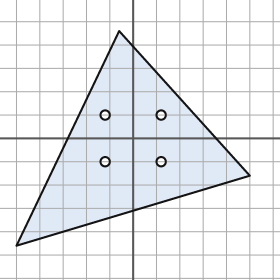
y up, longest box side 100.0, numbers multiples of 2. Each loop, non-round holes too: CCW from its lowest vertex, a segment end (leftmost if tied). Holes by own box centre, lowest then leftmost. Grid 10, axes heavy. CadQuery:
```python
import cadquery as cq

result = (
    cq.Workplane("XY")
    .moveTo(-50.0, -46.0)
    .lineTo(50.0, -16.0)
    .lineTo(-6.0, 46.0)
    .close()
    .moveTo(-12.0, -10.0)
    .circle(2.0)
    .moveTo(12.0, -10.0)
    .circle(2.0)
    .moveTo(-12.0, 10.0)
    .circle(2.0)
    .moveTo(12.0, 10.0)
    .circle(2.0)
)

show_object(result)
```